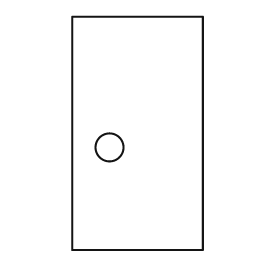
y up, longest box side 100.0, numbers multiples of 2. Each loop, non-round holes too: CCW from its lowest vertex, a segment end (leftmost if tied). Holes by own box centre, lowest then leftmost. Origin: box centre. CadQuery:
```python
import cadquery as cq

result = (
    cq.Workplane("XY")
    .moveTo(-28.0, -50.0)
    .lineTo(28.0, -50.0)
    .lineTo(28.0, 50.0)
    .lineTo(-28.0, 50.0)
    .close()
    .moveTo(-12.0, -6.0)
    .circle(6.0)
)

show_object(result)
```